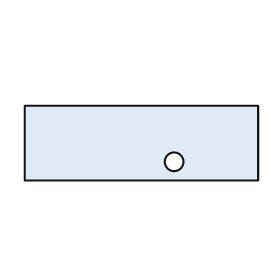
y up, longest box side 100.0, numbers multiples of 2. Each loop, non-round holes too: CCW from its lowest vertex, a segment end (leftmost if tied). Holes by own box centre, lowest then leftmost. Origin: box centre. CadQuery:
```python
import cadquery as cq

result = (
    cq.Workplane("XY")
    .moveTo(-50.0, -16.0)
    .lineTo(50.0, -16.0)
    .lineTo(50.0, 16.0)
    .lineTo(-50.0, 16.0)
    .close()
    .moveTo(14.0, -8.0)
    .circle(4.0)
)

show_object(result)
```